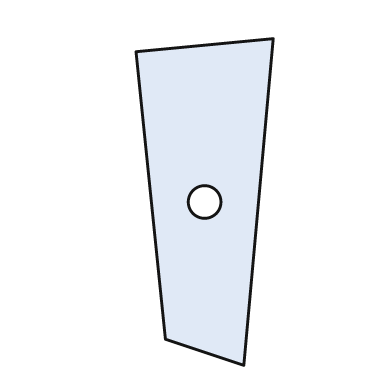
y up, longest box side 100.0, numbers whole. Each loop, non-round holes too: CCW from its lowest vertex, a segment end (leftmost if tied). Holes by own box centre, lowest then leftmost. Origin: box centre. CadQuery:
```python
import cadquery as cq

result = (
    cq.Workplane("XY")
    .moveTo(12.0, -50.0)
    .lineTo(21.0, 50.0)
    .lineTo(-21.0, 46.0)
    .lineTo(-12.0, -42.0)
    .close()
    .moveTo(0.0, 0.0)
    .circle(5.0)
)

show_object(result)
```